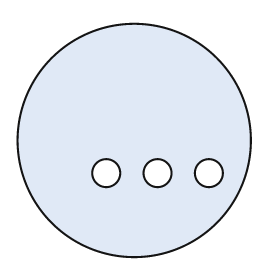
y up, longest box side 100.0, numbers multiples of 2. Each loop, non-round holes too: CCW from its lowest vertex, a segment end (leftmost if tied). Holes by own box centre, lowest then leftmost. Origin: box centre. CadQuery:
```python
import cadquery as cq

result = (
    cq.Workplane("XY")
    .moveTo(0.0, 0.0)
    .circle(50.0)
    .moveTo(-12.0, -14.0)
    .circle(6.0)
    .moveTo(10.0, -14.0)
    .circle(6.0)
    .moveTo(32.0, -14.0)
    .circle(6.0)
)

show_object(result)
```